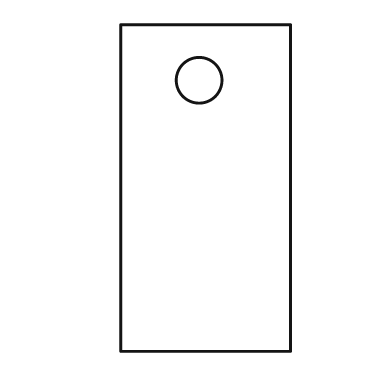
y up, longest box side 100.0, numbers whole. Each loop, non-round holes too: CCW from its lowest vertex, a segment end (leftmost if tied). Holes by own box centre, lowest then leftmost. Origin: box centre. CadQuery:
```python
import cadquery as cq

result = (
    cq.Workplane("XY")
    .moveTo(-26.0, -50.0)
    .lineTo(26.0, -50.0)
    .lineTo(26.0, 50.0)
    .lineTo(-26.0, 50.0)
    .close()
    .moveTo(-2.0, 33.0)
    .circle(7.0)
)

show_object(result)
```